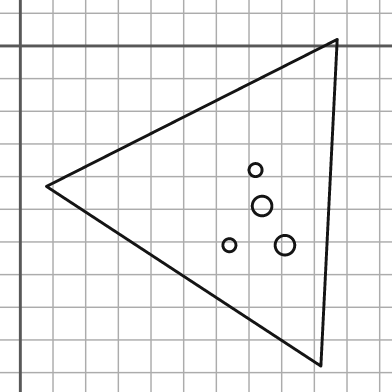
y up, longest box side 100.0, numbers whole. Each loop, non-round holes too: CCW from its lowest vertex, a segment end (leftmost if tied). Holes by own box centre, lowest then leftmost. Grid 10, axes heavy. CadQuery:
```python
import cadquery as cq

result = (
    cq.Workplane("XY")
    .moveTo(92.0, -98.0)
    .lineTo(97.0, 2.0)
    .lineTo(8.0, -43.0)
    .close()
    .moveTo(64.0, -61.0)
    .circle(2.0)
    .moveTo(81.0, -61.0)
    .circle(3.0)
    .moveTo(74.0, -49.0)
    .circle(3.0)
    .moveTo(72.0, -38.0)
    .circle(2.0)
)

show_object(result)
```